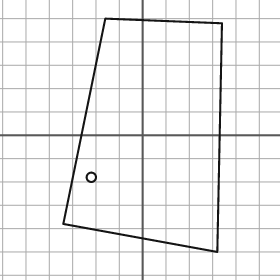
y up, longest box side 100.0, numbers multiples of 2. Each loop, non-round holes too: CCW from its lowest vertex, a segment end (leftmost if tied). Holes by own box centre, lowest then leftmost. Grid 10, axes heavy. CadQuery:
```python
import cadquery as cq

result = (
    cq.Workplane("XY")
    .moveTo(32.0, -50.0)
    .lineTo(34.0, 48.0)
    .lineTo(-16.0, 50.0)
    .lineTo(-34.0, -38.0)
    .close()
    .moveTo(-22.0, -18.0)
    .circle(2.0)
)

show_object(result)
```